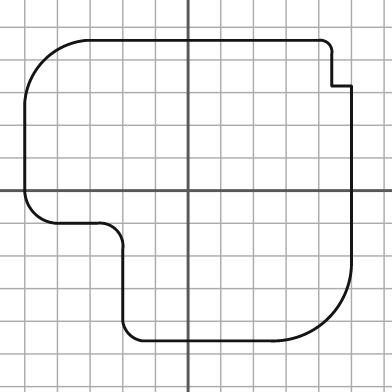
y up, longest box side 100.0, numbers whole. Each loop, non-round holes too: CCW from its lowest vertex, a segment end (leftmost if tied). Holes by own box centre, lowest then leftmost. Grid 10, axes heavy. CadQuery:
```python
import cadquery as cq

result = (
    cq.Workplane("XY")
    .moveTo(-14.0, -46.0)
    .lineTo(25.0, -46.0)
    .threePointArc((43.0, -39.0), (50.0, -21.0))
    .lineTo(50.0, 32.0)
    .lineTo(44.0, 32.0)
    .lineTo(44.0, 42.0)
    .threePointArc((43.0, 45.0), (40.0, 46.0))
    .lineTo(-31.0, 46.0)
    .threePointArc((-44.0, 40.0), (-50.0, 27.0))
    .lineTo(-50.0, 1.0)
    .threePointArc((-47.0, -7.0), (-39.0, -10.0))
    .lineTo(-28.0, -10.0)
    .threePointArc((-22.0, -12.0), (-20.0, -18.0))
    .lineTo(-20.0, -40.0)
    .threePointArc((-18.0, -44.0), (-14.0, -46.0))
    .close()
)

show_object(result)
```